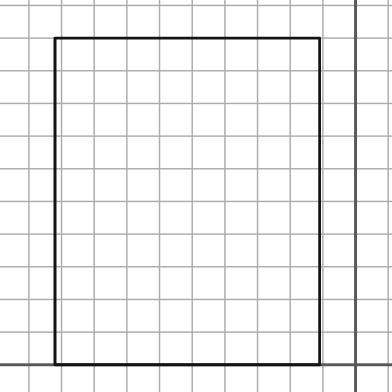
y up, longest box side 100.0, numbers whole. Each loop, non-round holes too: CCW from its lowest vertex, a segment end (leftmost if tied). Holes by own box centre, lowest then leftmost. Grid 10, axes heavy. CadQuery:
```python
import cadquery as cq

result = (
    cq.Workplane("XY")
    .moveTo(-92.0, 0.0)
    .lineTo(-11.0, 0.0)
    .lineTo(-11.0, 100.0)
    .lineTo(-92.0, 100.0)
    .close()
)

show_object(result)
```